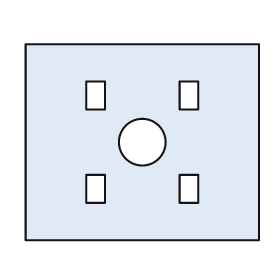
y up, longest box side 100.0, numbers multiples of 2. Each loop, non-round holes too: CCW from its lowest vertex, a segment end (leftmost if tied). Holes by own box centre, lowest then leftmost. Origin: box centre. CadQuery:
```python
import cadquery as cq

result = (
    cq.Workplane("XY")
    .moveTo(-50.0, -42.0)
    .lineTo(50.0, -42.0)
    .lineTo(50.0, 42.0)
    .lineTo(-50.0, 42.0)
    .close()
    .moveTo(-24.0, -26.0)
    .lineTo(-16.0, -26.0)
    .lineTo(-16.0, -14.0)
    .lineTo(-24.0, -14.0)
    .close()
    .moveTo(16.0, -26.0)
    .lineTo(24.0, -26.0)
    .lineTo(24.0, -14.0)
    .lineTo(16.0, -14.0)
    .close()
    .moveTo(0.0, 0.0)
    .circle(10.0)
    .moveTo(-24.0, 14.0)
    .lineTo(-16.0, 14.0)
    .lineTo(-16.0, 26.0)
    .lineTo(-24.0, 26.0)
    .close()
    .moveTo(16.0, 14.0)
    .lineTo(24.0, 14.0)
    .lineTo(24.0, 26.0)
    .lineTo(16.0, 26.0)
    .close()
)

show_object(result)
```